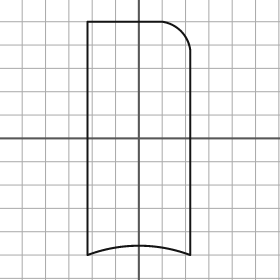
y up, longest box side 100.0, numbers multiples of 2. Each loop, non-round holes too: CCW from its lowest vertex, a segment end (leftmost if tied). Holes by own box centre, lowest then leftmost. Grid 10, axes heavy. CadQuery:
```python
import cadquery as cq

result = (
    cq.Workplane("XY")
    .moveTo(-22.0, -50.0)
    .threePointArc((0.0, -46.0), (22.0, -50.0))
    .lineTo(22.0, 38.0)
    .threePointArc((18.0, 46.0), (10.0, 50.0))
    .lineTo(-22.0, 50.0)
    .close()
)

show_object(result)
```